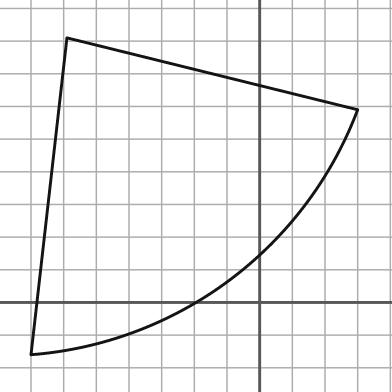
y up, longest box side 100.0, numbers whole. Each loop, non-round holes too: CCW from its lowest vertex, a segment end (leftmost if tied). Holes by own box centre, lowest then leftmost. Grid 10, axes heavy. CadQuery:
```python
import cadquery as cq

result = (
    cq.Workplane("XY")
    .moveTo(-70.0, -16.0)
    .threePointArc((-9.0, 7.0), (30.0, 59.0))
    .lineTo(-59.0, 81.0)
    .close()
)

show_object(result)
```